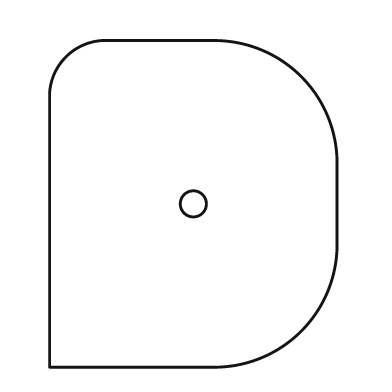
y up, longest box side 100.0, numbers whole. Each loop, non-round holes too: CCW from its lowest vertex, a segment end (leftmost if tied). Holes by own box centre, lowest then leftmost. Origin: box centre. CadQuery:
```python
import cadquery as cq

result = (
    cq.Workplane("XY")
    .moveTo(-44.0, -50.0)
    .lineTo(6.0, -50.0)
    .threePointArc((33.0, -39.0), (44.0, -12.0))
    .lineTo(44.0, 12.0)
    .threePointArc((33.0, 39.0), (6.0, 50.0))
    .lineTo(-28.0, 50.0)
    .threePointArc((-39.0, 45.0), (-44.0, 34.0))
    .close()
    .moveTo(0.0, 0.0)
    .circle(4.0)
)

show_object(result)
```